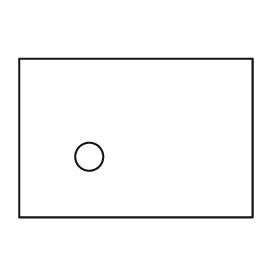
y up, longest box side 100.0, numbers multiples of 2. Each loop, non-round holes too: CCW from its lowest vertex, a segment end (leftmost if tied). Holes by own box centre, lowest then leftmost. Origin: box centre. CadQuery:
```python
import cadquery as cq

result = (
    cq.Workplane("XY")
    .moveTo(-50.0, -34.0)
    .lineTo(50.0, -34.0)
    .lineTo(50.0, 34.0)
    .lineTo(-50.0, 34.0)
    .close()
    .moveTo(-20.0, -8.0)
    .circle(6.0)
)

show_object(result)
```